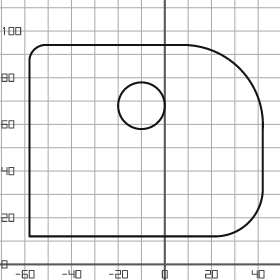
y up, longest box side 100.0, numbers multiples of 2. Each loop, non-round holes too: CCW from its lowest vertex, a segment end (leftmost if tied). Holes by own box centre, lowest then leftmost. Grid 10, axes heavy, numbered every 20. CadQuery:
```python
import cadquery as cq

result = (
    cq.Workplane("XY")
    .moveTo(-58.0, 12.0)
    .lineTo(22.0, 12.0)
    .threePointArc((36.0, 18.0), (42.0, 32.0))
    .lineTo(42.0, 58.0)
    .threePointArc((32.0, 84.0), (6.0, 94.0))
    .lineTo(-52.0, 94.0)
    .threePointArc((-56.0, 92.0), (-58.0, 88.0))
    .close()
    .moveTo(-10.0, 68.0)
    .circle(10.0)
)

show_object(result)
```